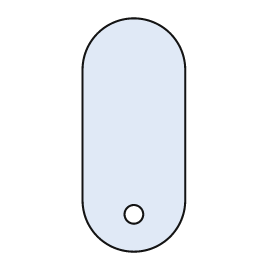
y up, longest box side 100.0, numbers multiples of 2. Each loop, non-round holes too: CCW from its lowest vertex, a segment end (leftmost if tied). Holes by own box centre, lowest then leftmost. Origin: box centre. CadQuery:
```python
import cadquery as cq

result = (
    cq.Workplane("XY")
    .moveTo(-22.0, -28.0)
    .threePointArc((0.0, -50.0), (22.0, -28.0))
    .lineTo(22.0, 28.0)
    .threePointArc((0.0, 50.0), (-22.0, 28.0))
    .close()
    .moveTo(0.0, -34.0)
    .circle(4.0)
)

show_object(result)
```